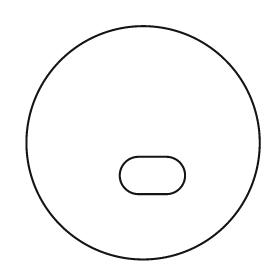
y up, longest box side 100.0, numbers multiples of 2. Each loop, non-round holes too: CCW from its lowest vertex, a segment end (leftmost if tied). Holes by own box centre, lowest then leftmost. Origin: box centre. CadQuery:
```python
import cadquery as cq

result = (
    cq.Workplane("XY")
    .moveTo(0.0, 0.0)
    .circle(50.0)
    .moveTo(-2.0, -22.0)
    .lineTo(10.0, -22.0)
    .threePointArc((18.0, -14.0), (10.0, -6.0))
    .lineTo(-2.0, -6.0)
    .threePointArc((-10.0, -14.0), (-2.0, -22.0))
    .close()
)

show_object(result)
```